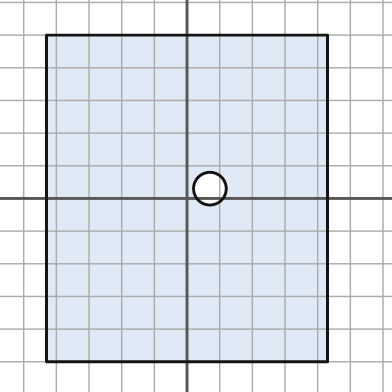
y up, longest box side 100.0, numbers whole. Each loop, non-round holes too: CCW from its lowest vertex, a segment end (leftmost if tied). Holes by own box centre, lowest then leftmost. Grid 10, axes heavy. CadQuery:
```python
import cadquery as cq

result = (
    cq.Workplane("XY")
    .moveTo(-43.0, -50.0)
    .lineTo(43.0, -50.0)
    .lineTo(43.0, 50.0)
    .lineTo(-43.0, 50.0)
    .close()
    .moveTo(7.0, 3.0)
    .circle(5.0)
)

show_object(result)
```